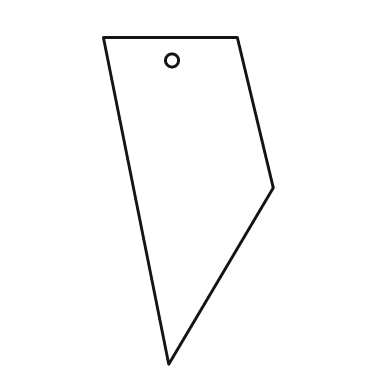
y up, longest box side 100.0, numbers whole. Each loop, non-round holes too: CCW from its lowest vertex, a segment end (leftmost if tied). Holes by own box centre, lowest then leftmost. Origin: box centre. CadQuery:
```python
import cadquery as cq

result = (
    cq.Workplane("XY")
    .moveTo(-6.0, -50.0)
    .lineTo(26.0, 4.0)
    .lineTo(15.0, 50.0)
    .lineTo(-26.0, 50.0)
    .close()
    .moveTo(-5.0, 43.0)
    .circle(2.0)
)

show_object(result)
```